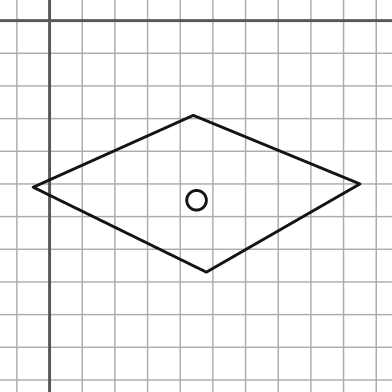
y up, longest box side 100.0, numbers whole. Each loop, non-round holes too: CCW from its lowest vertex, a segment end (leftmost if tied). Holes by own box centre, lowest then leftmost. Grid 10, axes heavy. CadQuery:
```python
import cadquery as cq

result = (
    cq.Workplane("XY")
    .moveTo(48.0, -77.0)
    .lineTo(95.0, -50.0)
    .lineTo(44.0, -29.0)
    .lineTo(-5.0, -51.0)
    .close()
    .moveTo(45.0, -55.0)
    .circle(3.0)
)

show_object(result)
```